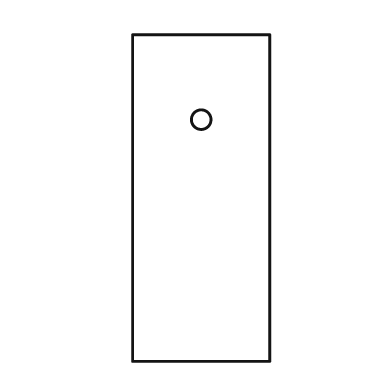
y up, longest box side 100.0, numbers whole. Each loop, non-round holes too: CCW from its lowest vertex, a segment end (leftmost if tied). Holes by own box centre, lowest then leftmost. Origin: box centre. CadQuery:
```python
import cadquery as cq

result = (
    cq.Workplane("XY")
    .moveTo(-21.0, -50.0)
    .lineTo(21.0, -50.0)
    .lineTo(21.0, 50.0)
    .lineTo(-21.0, 50.0)
    .close()
    .moveTo(0.0, 24.0)
    .circle(3.0)
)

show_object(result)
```